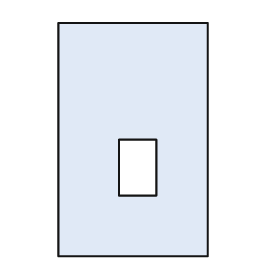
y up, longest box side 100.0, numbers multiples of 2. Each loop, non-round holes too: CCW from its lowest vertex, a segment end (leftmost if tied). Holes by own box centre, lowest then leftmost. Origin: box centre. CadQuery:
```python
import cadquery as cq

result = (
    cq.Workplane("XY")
    .moveTo(-32.0, -50.0)
    .lineTo(32.0, -50.0)
    .lineTo(32.0, 50.0)
    .lineTo(-32.0, 50.0)
    .close()
    .moveTo(-6.0, -24.0)
    .lineTo(10.0, -24.0)
    .lineTo(10.0, 0.0)
    .lineTo(-6.0, 0.0)
    .close()
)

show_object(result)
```